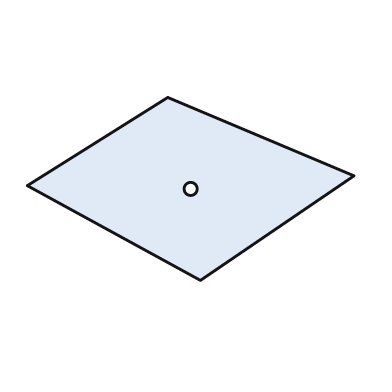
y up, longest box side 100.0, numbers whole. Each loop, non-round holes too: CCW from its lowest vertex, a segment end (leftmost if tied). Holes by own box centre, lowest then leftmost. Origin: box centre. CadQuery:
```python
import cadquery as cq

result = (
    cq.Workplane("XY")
    .moveTo(3.0, -28.0)
    .lineTo(50.0, 4.0)
    .lineTo(-7.0, 28.0)
    .lineTo(-50.0, 1.0)
    .close()
    .moveTo(0.0, 0.0)
    .circle(2.0)
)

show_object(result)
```